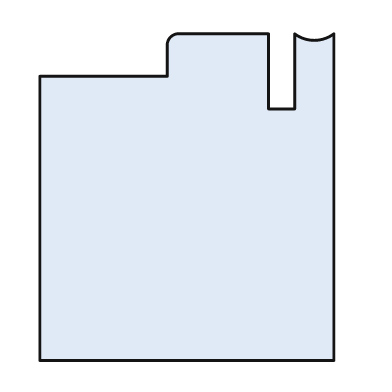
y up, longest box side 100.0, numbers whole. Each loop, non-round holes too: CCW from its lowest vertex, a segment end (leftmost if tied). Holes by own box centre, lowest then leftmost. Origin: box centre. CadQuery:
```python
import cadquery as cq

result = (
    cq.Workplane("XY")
    .moveTo(-45.0, -50.0)
    .lineTo(45.0, -50.0)
    .lineTo(45.0, 50.0)
    .threePointArc((39.0, 48.0), (33.0, 50.0))
    .lineTo(33.0, 27.0)
    .lineTo(25.0, 27.0)
    .lineTo(25.0, 50.0)
    .lineTo(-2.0, 50.0)
    .threePointArc((-5.0, 49.0), (-6.0, 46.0))
    .lineTo(-6.0, 37.0)
    .lineTo(-45.0, 37.0)
    .close()
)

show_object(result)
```